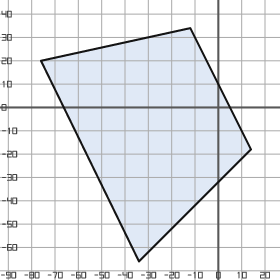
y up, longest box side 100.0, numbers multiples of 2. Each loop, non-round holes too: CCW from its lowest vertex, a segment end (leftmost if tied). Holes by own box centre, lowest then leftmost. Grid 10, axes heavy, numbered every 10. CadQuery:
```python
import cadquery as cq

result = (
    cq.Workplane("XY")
    .moveTo(-34.0, -66.0)
    .lineTo(14.0, -18.0)
    .lineTo(-12.0, 34.0)
    .lineTo(-76.0, 20.0)
    .close()
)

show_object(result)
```